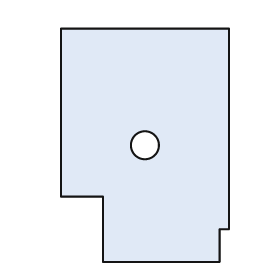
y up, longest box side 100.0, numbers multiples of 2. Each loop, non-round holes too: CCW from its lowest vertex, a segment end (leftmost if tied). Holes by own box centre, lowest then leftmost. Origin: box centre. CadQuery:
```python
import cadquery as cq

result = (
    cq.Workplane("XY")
    .moveTo(-18.0, -50.0)
    .lineTo(32.0, -50.0)
    .lineTo(32.0, -36.0)
    .lineTo(36.0, -36.0)
    .lineTo(36.0, 50.0)
    .lineTo(-36.0, 50.0)
    .lineTo(-36.0, -22.0)
    .lineTo(-18.0, -22.0)
    .close()
    .moveTo(0.0, 0.0)
    .circle(6.0)
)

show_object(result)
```